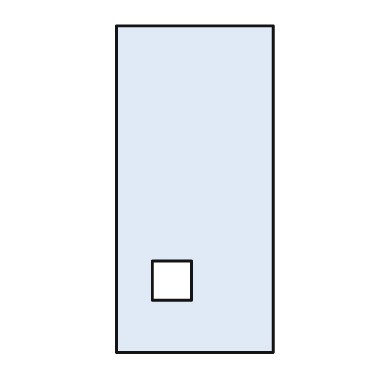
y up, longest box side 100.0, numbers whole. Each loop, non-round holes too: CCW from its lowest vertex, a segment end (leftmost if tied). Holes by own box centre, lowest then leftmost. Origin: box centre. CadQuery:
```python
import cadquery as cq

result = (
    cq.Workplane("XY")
    .moveTo(-24.0, -50.0)
    .lineTo(24.0, -50.0)
    .lineTo(24.0, 50.0)
    .lineTo(-24.0, 50.0)
    .close()
    .moveTo(-13.0, -34.0)
    .lineTo(-1.0, -34.0)
    .lineTo(-1.0, -22.0)
    .lineTo(-13.0, -22.0)
    .close()
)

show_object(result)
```